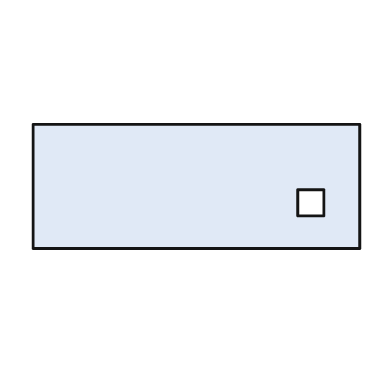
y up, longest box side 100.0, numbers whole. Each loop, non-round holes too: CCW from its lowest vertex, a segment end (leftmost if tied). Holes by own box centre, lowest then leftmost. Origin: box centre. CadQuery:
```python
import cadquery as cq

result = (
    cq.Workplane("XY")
    .moveTo(-50.0, -19.0)
    .lineTo(50.0, -19.0)
    .lineTo(50.0, 19.0)
    .lineTo(-50.0, 19.0)
    .close()
    .moveTo(31.0, -9.0)
    .lineTo(39.0, -9.0)
    .lineTo(39.0, -1.0)
    .lineTo(31.0, -1.0)
    .close()
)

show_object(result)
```